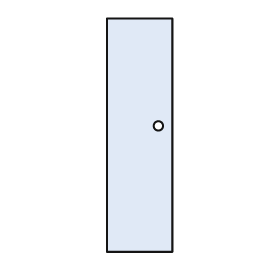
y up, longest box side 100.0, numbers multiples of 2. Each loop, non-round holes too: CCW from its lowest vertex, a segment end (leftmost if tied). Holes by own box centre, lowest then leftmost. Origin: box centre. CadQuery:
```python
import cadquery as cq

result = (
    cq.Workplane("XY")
    .moveTo(-14.0, -50.0)
    .lineTo(14.0, -50.0)
    .lineTo(14.0, 50.0)
    .lineTo(-14.0, 50.0)
    .close()
    .moveTo(8.0, 4.0)
    .circle(2.0)
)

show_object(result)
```